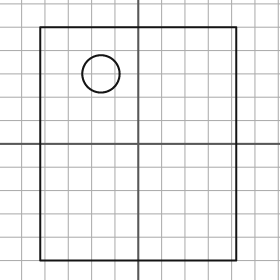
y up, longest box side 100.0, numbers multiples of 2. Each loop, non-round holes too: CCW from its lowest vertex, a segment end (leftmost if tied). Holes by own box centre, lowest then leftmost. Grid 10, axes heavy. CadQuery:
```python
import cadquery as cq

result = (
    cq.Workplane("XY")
    .moveTo(-42.0, -50.0)
    .lineTo(42.0, -50.0)
    .lineTo(42.0, 50.0)
    .lineTo(-42.0, 50.0)
    .close()
    .moveTo(-16.0, 30.0)
    .circle(8.0)
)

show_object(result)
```